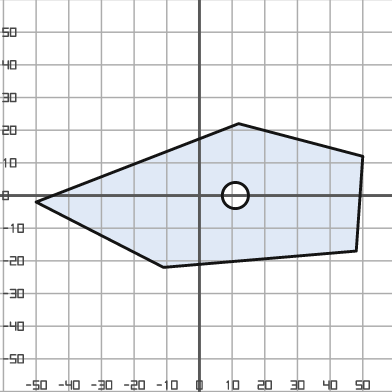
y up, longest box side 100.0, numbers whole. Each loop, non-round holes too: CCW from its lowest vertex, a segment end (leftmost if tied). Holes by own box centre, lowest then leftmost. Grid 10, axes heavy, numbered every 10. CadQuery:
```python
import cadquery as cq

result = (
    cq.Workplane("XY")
    .moveTo(-11.0, -22.0)
    .lineTo(48.0, -17.0)
    .lineTo(50.0, 12.0)
    .lineTo(12.0, 22.0)
    .lineTo(-50.0, -2.0)
    .close()
    .moveTo(11.0, 0.0)
    .circle(4.0)
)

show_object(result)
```